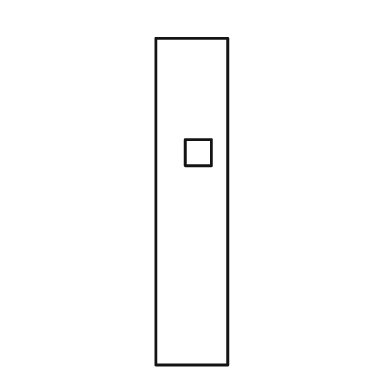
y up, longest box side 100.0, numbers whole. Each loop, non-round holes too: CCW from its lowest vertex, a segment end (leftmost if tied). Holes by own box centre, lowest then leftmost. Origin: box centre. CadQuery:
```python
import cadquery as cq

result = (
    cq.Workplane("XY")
    .moveTo(-11.0, -50.0)
    .lineTo(11.0, -50.0)
    .lineTo(11.0, 50.0)
    .lineTo(-11.0, 50.0)
    .close()
    .moveTo(-2.0, 11.0)
    .lineTo(6.0, 11.0)
    .lineTo(6.0, 19.0)
    .lineTo(-2.0, 19.0)
    .close()
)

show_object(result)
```